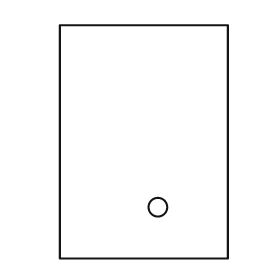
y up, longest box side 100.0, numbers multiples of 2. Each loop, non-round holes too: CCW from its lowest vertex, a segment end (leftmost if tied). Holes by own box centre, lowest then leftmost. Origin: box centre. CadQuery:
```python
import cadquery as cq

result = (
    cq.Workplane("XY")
    .moveTo(-36.0, -50.0)
    .lineTo(36.0, -50.0)
    .lineTo(36.0, 50.0)
    .lineTo(-36.0, 50.0)
    .close()
    .moveTo(6.0, -28.0)
    .circle(4.0)
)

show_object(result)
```